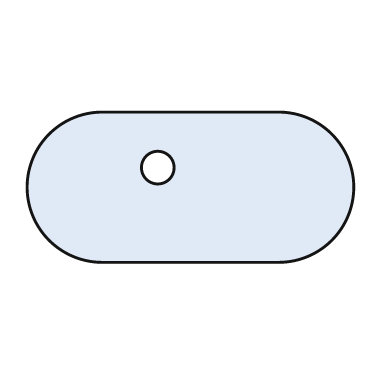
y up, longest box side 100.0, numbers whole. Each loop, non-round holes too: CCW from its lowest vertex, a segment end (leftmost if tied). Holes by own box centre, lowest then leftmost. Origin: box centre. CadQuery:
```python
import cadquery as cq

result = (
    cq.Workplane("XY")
    .moveTo(-27.0, -23.0)
    .lineTo(27.0, -23.0)
    .threePointArc((50.0, 0.0), (27.0, 23.0))
    .lineTo(-27.0, 23.0)
    .threePointArc((-50.0, 0.0), (-27.0, -23.0))
    .close()
    .moveTo(-10.0, 6.0)
    .circle(5.0)
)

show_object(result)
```